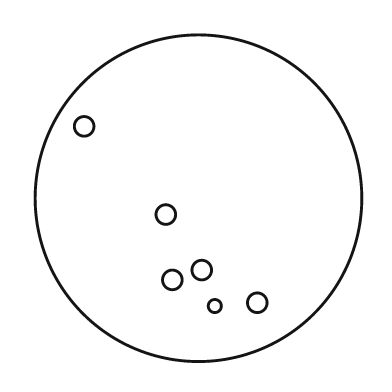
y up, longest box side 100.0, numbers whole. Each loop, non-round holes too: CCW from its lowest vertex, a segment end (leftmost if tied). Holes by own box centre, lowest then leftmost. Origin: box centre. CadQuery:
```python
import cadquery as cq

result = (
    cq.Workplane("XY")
    .moveTo(0.0, 0.0)
    .circle(50.0)
    .moveTo(5.0, -33.0)
    .circle(2.0)
    .moveTo(18.0, -32.0)
    .circle(3.0)
    .moveTo(-8.0, -25.0)
    .circle(3.0)
    .moveTo(1.0, -22.0)
    .circle(3.0)
    .moveTo(-10.0, -5.0)
    .circle(3.0)
    .moveTo(-35.0, 22.0)
    .circle(3.0)
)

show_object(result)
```